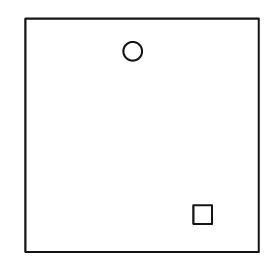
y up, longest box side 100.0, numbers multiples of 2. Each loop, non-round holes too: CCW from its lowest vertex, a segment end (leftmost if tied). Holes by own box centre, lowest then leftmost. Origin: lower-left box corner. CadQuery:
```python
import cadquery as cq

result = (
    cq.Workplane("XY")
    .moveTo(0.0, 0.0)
    .lineTo(100.0, 0.0)
    .lineTo(100.0, 100.0)
    .lineTo(0.0, 100.0)
    .close()
    .moveTo(72.0, 12.0)
    .lineTo(80.0, 12.0)
    .lineTo(80.0, 20.0)
    .lineTo(72.0, 20.0)
    .close()
    .moveTo(46.0, 86.0)
    .circle(4.0)
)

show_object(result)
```